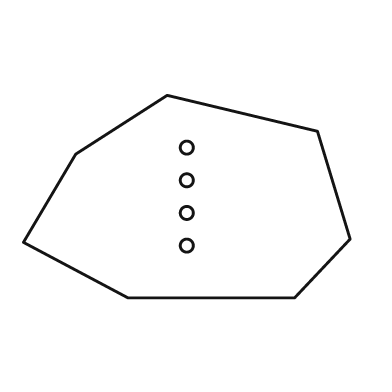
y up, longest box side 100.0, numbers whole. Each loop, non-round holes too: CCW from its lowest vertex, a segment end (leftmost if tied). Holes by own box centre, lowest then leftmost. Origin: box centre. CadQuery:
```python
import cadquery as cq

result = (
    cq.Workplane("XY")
    .moveTo(-18.0, -31.0)
    .lineTo(33.0, -31.0)
    .lineTo(50.0, -13.0)
    .lineTo(40.0, 20.0)
    .lineTo(-6.0, 31.0)
    .lineTo(-34.0, 13.0)
    .lineTo(-50.0, -14.0)
    .close()
    .moveTo(0.0, -15.0)
    .circle(2.0)
    .moveTo(0.0, -5.0)
    .circle(2.0)
    .moveTo(0.0, 5.0)
    .circle(2.0)
    .moveTo(0.0, 15.0)
    .circle(2.0)
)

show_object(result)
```